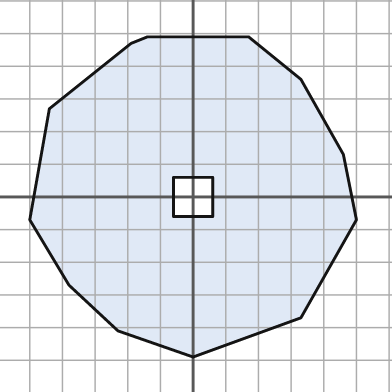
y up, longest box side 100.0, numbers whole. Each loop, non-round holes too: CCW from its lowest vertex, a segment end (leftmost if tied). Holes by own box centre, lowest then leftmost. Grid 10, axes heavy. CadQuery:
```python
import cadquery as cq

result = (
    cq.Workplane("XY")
    .moveTo(0.0, -49.0)
    .lineTo(33.0, -37.0)
    .lineTo(50.0, -7.0)
    .lineTo(46.0, 13.0)
    .lineTo(33.0, 36.0)
    .lineTo(17.0, 49.0)
    .lineTo(-14.0, 49.0)
    .lineTo(-19.0, 47.0)
    .lineTo(-44.0, 27.0)
    .lineTo(-50.0, -7.0)
    .lineTo(-38.0, -27.0)
    .lineTo(-23.0, -41.0)
    .close()
    .moveTo(-6.0, -6.0)
    .lineTo(6.0, -6.0)
    .lineTo(6.0, 6.0)
    .lineTo(-6.0, 6.0)
    .close()
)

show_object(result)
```